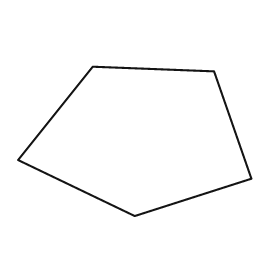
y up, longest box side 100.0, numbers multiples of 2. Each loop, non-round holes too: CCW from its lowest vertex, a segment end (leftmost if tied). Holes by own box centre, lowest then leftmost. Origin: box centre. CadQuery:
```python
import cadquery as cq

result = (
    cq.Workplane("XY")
    .moveTo(0.0, -32.0)
    .lineTo(50.0, -16.0)
    .lineTo(34.0, 30.0)
    .lineTo(-18.0, 32.0)
    .lineTo(-50.0, -8.0)
    .close()
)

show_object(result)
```